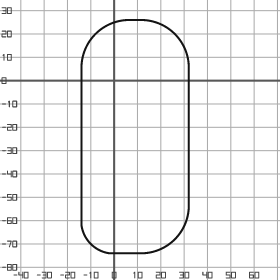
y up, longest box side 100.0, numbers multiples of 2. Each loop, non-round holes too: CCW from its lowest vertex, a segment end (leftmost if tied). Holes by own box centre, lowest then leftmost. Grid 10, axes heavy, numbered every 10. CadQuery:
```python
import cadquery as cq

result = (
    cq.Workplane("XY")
    .moveTo(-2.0, -74.0)
    .lineTo(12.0, -74.0)
    .threePointArc((26.0, -68.0), (32.0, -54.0))
    .lineTo(32.0, 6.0)
    .threePointArc((26.0, 20.0), (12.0, 26.0))
    .lineTo(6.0, 26.0)
    .threePointArc((-8.0, 20.0), (-14.0, 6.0))
    .lineTo(-14.0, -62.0)
    .threePointArc((-10.0, -70.0), (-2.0, -74.0))
    .close()
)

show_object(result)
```